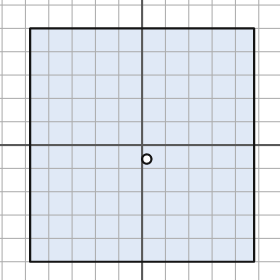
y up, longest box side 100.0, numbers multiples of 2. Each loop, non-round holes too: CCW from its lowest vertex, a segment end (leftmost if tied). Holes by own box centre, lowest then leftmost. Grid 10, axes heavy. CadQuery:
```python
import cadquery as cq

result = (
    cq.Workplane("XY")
    .moveTo(-48.0, -50.0)
    .lineTo(48.0, -50.0)
    .lineTo(48.0, 50.0)
    .lineTo(-48.0, 50.0)
    .close()
    .moveTo(2.0, -6.0)
    .circle(2.0)
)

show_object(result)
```